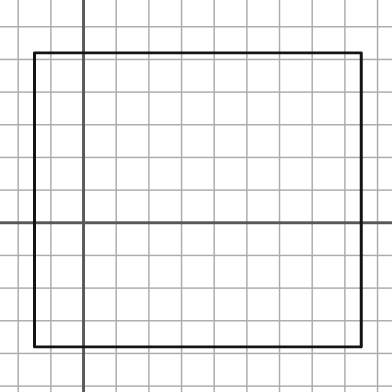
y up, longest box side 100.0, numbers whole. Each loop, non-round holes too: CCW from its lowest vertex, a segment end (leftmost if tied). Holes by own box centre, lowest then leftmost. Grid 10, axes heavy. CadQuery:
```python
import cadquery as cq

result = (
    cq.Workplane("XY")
    .moveTo(-15.0, -38.0)
    .lineTo(85.0, -38.0)
    .lineTo(85.0, 52.0)
    .lineTo(-15.0, 52.0)
    .close()
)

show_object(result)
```